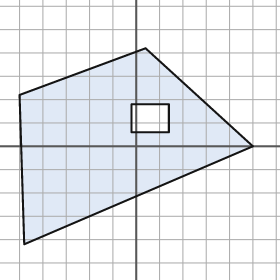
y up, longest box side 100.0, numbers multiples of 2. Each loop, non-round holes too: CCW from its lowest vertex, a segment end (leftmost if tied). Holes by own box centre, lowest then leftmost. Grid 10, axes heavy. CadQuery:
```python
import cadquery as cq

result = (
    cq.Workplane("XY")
    .moveTo(-48.0, -42.0)
    .lineTo(50.0, 0.0)
    .lineTo(4.0, 42.0)
    .lineTo(-50.0, 22.0)
    .close()
    .moveTo(-2.0, 6.0)
    .lineTo(14.0, 6.0)
    .lineTo(14.0, 18.0)
    .lineTo(-2.0, 18.0)
    .close()
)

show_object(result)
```